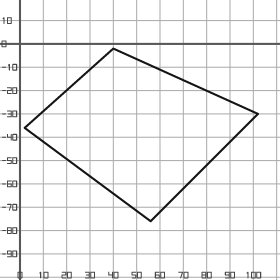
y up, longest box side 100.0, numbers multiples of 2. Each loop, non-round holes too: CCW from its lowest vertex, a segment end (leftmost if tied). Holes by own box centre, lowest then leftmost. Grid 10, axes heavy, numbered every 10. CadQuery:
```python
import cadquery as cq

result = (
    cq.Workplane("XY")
    .moveTo(56.0, -76.0)
    .lineTo(102.0, -30.0)
    .lineTo(40.0, -2.0)
    .lineTo(2.0, -36.0)
    .close()
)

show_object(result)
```